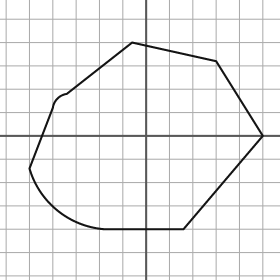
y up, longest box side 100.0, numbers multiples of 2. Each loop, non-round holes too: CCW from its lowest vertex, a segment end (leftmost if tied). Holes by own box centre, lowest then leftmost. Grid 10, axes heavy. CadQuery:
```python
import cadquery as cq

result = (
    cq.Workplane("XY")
    .moveTo(-18.0, -40.0)
    .lineTo(16.0, -40.0)
    .lineTo(50.0, 0.0)
    .lineTo(30.0, 32.0)
    .lineTo(-6.0, 40.0)
    .lineTo(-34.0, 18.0)
    .threePointArc((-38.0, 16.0), (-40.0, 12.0))
    .lineTo(-50.0, -14.0)
    .threePointArc((-38.0, -32.0), (-18.0, -40.0))
    .close()
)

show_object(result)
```